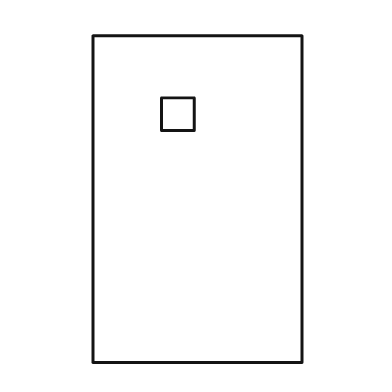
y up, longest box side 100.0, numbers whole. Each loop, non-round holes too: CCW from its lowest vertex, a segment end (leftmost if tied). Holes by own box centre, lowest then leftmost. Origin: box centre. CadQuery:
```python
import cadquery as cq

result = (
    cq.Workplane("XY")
    .moveTo(-32.0, -50.0)
    .lineTo(32.0, -50.0)
    .lineTo(32.0, 50.0)
    .lineTo(-32.0, 50.0)
    .close()
    .moveTo(-11.0, 21.0)
    .lineTo(-1.0, 21.0)
    .lineTo(-1.0, 31.0)
    .lineTo(-11.0, 31.0)
    .close()
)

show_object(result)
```